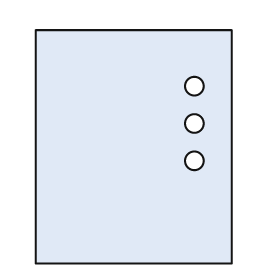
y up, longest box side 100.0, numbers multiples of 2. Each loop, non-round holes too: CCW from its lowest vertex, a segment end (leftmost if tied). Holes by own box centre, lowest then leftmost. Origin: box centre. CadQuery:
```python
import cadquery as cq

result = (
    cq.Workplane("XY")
    .moveTo(-42.0, -50.0)
    .lineTo(42.0, -50.0)
    .lineTo(42.0, 50.0)
    .lineTo(-42.0, 50.0)
    .close()
    .moveTo(26.0, -6.0)
    .circle(4.0)
    .moveTo(26.0, 10.0)
    .circle(4.0)
    .moveTo(26.0, 26.0)
    .circle(4.0)
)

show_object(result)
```